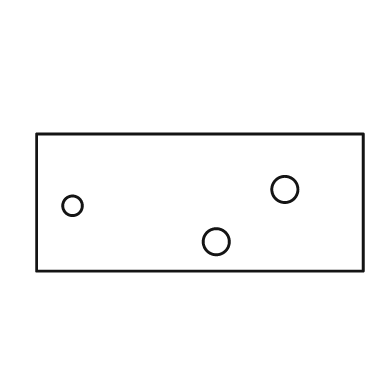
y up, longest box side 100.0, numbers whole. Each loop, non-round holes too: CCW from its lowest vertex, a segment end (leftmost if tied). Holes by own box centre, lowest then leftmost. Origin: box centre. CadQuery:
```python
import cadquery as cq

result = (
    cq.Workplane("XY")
    .moveTo(-50.0, -21.0)
    .lineTo(50.0, -21.0)
    .lineTo(50.0, 21.0)
    .lineTo(-50.0, 21.0)
    .close()
    .moveTo(5.0, -12.0)
    .circle(4.0)
    .moveTo(-39.0, -1.0)
    .circle(3.0)
    .moveTo(26.0, 4.0)
    .circle(4.0)
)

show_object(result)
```